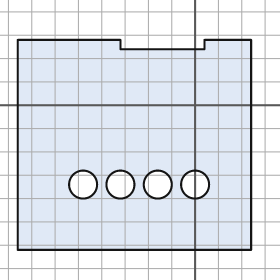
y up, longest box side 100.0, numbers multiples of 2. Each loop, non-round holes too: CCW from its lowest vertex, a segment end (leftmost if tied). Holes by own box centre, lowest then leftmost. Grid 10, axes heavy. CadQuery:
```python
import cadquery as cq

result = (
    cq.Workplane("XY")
    .moveTo(-76.0, -62.0)
    .lineTo(24.0, -62.0)
    .lineTo(24.0, 28.0)
    .lineTo(4.0, 28.0)
    .lineTo(4.0, 24.0)
    .lineTo(-32.0, 24.0)
    .lineTo(-32.0, 28.0)
    .lineTo(-76.0, 28.0)
    .close()
    .moveTo(-48.0, -34.0)
    .circle(6.0)
    .moveTo(-32.0, -34.0)
    .circle(6.0)
    .moveTo(-16.0, -34.0)
    .circle(6.0)
    .moveTo(0.0, -34.0)
    .circle(6.0)
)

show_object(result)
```